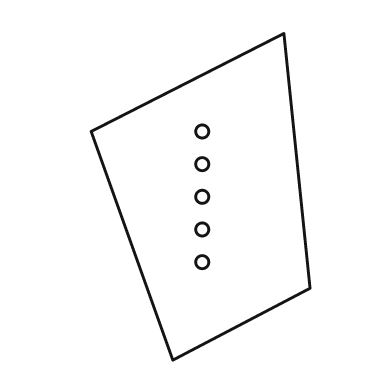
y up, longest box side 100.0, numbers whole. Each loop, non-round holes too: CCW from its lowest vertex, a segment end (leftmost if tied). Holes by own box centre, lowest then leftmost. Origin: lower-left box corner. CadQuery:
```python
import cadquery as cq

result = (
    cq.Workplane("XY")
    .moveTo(25.0, 0.0)
    .lineTo(67.0, 22.0)
    .lineTo(59.0, 100.0)
    .lineTo(0.0, 70.0)
    .close()
    .moveTo(34.0, 30.0)
    .circle(2.0)
    .moveTo(34.0, 40.0)
    .circle(2.0)
    .moveTo(34.0, 50.0)
    .circle(2.0)
    .moveTo(34.0, 60.0)
    .circle(2.0)
    .moveTo(34.0, 70.0)
    .circle(2.0)
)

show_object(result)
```